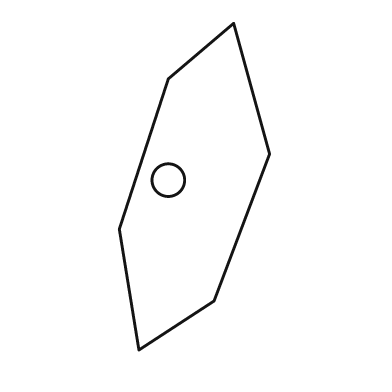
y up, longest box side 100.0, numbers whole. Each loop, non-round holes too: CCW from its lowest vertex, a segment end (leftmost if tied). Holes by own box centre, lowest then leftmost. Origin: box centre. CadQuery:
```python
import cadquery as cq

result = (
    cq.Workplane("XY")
    .moveTo(-17.0, -50.0)
    .lineTo(6.0, -35.0)
    .lineTo(23.0, 10.0)
    .lineTo(12.0, 50.0)
    .lineTo(-8.0, 33.0)
    .lineTo(-23.0, -13.0)
    .close()
    .moveTo(-8.0, 2.0)
    .circle(5.0)
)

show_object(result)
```